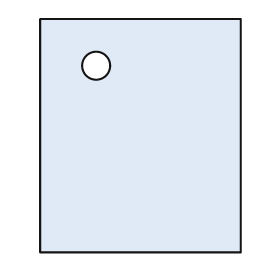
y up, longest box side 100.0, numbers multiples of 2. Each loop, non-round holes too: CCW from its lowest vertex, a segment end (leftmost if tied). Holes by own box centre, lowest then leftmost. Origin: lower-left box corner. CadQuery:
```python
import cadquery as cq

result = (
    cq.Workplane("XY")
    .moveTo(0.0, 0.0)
    .lineTo(86.0, 0.0)
    .lineTo(86.0, 100.0)
    .lineTo(0.0, 100.0)
    .close()
    .moveTo(24.0, 80.0)
    .circle(6.0)
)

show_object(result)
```